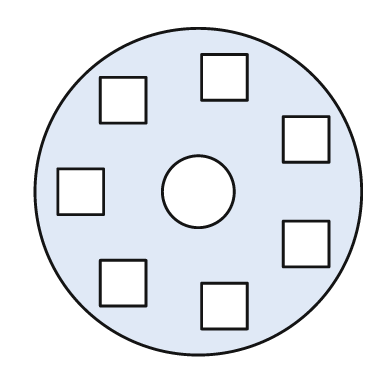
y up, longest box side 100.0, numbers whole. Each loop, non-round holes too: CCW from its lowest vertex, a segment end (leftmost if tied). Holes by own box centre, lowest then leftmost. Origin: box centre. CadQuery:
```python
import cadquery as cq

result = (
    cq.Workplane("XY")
    .moveTo(0.0, 0.0)
    .circle(50.0)
    .moveTo(1.0, -42.0)
    .lineTo(15.0, -42.0)
    .lineTo(15.0, -28.0)
    .lineTo(1.0, -28.0)
    .close()
    .moveTo(-30.0, -35.0)
    .lineTo(-16.0, -35.0)
    .lineTo(-16.0, -21.0)
    .lineTo(-30.0, -21.0)
    .close()
    .moveTo(26.0, -23.0)
    .lineTo(40.0, -23.0)
    .lineTo(40.0, -9.0)
    .lineTo(26.0, -9.0)
    .close()
    .moveTo(-43.0, -7.0)
    .lineTo(-29.0, -7.0)
    .lineTo(-29.0, 7.0)
    .lineTo(-43.0, 7.0)
    .close()
    .moveTo(0.0, 0.0)
    .circle(11.0)
    .moveTo(26.0, 9.0)
    .lineTo(40.0, 9.0)
    .lineTo(40.0, 23.0)
    .lineTo(26.0, 23.0)
    .close()
    .moveTo(-30.0, 21.0)
    .lineTo(-16.0, 21.0)
    .lineTo(-16.0, 35.0)
    .lineTo(-30.0, 35.0)
    .close()
    .moveTo(1.0, 28.0)
    .lineTo(15.0, 28.0)
    .lineTo(15.0, 42.0)
    .lineTo(1.0, 42.0)
    .close()
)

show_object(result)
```